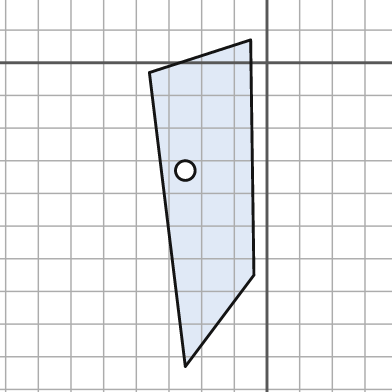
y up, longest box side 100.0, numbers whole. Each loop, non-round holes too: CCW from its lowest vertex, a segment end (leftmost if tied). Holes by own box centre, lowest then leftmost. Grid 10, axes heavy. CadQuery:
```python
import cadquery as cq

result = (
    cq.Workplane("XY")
    .moveTo(-25.0, -93.0)
    .lineTo(-4.0, -65.0)
    .lineTo(-5.0, 7.0)
    .lineTo(-36.0, -3.0)
    .close()
    .moveTo(-25.0, -33.0)
    .circle(3.0)
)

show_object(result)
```